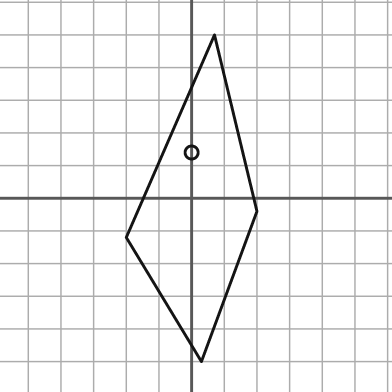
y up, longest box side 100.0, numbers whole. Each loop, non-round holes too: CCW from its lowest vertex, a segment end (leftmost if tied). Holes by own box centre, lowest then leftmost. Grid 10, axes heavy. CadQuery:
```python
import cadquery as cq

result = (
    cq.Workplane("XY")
    .moveTo(3.0, -50.0)
    .lineTo(20.0, -4.0)
    .lineTo(7.0, 50.0)
    .lineTo(-20.0, -12.0)
    .close()
    .moveTo(0.0, 14.0)
    .circle(2.0)
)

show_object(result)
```